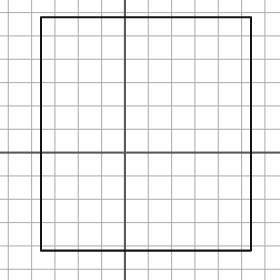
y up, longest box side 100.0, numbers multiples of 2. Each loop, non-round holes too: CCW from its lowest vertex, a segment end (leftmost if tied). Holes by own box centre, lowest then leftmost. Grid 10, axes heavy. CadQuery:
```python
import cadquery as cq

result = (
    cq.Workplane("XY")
    .moveTo(-36.0, -42.0)
    .lineTo(54.0, -42.0)
    .lineTo(54.0, 58.0)
    .lineTo(-36.0, 58.0)
    .close()
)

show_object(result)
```